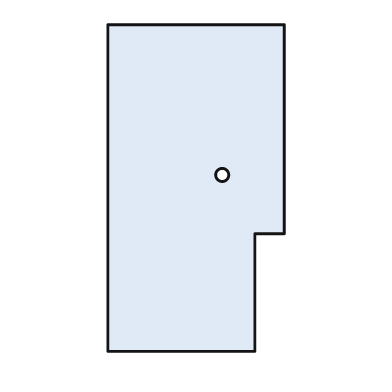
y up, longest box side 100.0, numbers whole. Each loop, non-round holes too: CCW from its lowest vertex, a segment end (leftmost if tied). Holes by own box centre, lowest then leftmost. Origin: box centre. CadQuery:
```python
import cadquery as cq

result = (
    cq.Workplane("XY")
    .moveTo(-27.0, -50.0)
    .lineTo(18.0, -50.0)
    .lineTo(18.0, -14.0)
    .lineTo(27.0, -14.0)
    .lineTo(27.0, 50.0)
    .lineTo(-27.0, 50.0)
    .close()
    .moveTo(8.0, 4.0)
    .circle(2.0)
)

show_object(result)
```